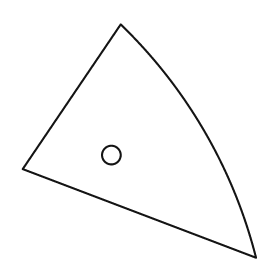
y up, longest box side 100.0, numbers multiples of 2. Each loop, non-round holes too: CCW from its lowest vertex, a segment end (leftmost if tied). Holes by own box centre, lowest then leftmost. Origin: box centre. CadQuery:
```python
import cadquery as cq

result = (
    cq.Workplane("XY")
    .moveTo(50.0, -50.0)
    .threePointArc((28.0, 4.0), (-8.0, 50.0))
    .lineTo(-50.0, -12.0)
    .close()
    .moveTo(-12.0, -6.0)
    .circle(4.0)
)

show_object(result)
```